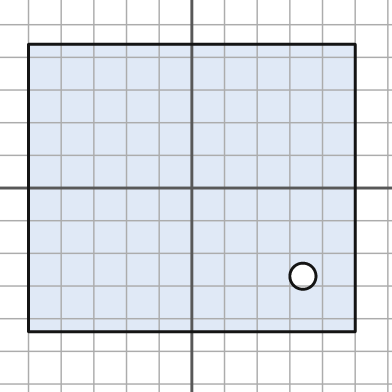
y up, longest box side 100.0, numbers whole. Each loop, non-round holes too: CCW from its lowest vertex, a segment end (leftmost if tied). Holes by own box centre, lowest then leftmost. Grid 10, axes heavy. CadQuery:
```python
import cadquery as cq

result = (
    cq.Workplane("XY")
    .moveTo(-50.0, -44.0)
    .lineTo(50.0, -44.0)
    .lineTo(50.0, 44.0)
    .lineTo(-50.0, 44.0)
    .close()
    .moveTo(34.0, -27.0)
    .circle(4.0)
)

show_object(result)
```